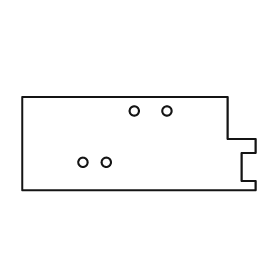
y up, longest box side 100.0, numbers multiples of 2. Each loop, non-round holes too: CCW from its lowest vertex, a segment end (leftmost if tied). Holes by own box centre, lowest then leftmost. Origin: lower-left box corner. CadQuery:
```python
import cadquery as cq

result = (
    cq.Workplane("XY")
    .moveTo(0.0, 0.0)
    .lineTo(100.0, 0.0)
    .lineTo(100.0, 4.0)
    .lineTo(94.0, 4.0)
    .lineTo(94.0, 16.0)
    .lineTo(100.0, 16.0)
    .lineTo(100.0, 22.0)
    .lineTo(88.0, 22.0)
    .lineTo(88.0, 40.0)
    .lineTo(0.0, 40.0)
    .close()
    .moveTo(26.0, 12.0)
    .circle(2.0)
    .moveTo(36.0, 12.0)
    .circle(2.0)
    .moveTo(48.0, 34.0)
    .circle(2.0)
    .moveTo(62.0, 34.0)
    .circle(2.0)
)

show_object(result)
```